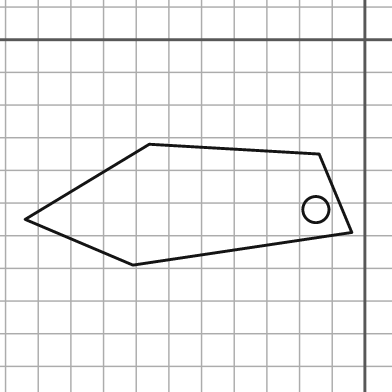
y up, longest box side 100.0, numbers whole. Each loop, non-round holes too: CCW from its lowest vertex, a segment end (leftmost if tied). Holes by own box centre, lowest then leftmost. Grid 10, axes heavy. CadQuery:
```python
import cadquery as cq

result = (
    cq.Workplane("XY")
    .moveTo(-71.0, -69.0)
    .lineTo(-4.0, -59.0)
    .lineTo(-14.0, -35.0)
    .lineTo(-66.0, -32.0)
    .lineTo(-104.0, -55.0)
    .close()
    .moveTo(-15.0, -52.0)
    .circle(4.0)
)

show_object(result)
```